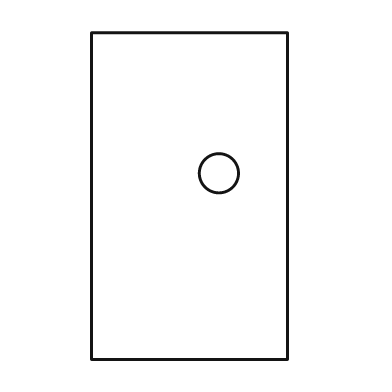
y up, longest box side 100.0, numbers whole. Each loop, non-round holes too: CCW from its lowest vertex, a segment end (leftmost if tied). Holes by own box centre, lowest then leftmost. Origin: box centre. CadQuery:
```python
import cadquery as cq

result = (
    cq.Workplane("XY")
    .moveTo(-30.0, -50.0)
    .lineTo(30.0, -50.0)
    .lineTo(30.0, 50.0)
    .lineTo(-30.0, 50.0)
    .close()
    .moveTo(9.0, 7.0)
    .circle(6.0)
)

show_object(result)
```